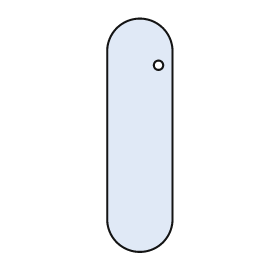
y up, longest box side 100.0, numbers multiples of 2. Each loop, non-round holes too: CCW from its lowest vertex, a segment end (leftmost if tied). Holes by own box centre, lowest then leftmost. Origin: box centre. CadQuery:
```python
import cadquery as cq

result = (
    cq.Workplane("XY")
    .moveTo(-14.0, -36.0)
    .threePointArc((0.0, -50.0), (14.0, -36.0))
    .lineTo(14.0, 36.0)
    .threePointArc((0.0, 50.0), (-14.0, 36.0))
    .close()
    .moveTo(8.0, 30.0)
    .circle(2.0)
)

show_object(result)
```